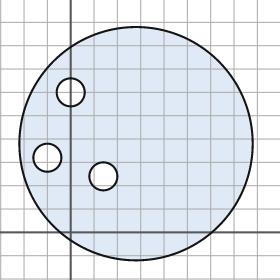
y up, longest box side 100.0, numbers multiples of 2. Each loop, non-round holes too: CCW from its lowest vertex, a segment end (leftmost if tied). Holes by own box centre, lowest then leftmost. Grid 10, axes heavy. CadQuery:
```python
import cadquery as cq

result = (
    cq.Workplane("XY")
    .moveTo(28.0, 38.0)
    .circle(50.0)
    .moveTo(14.0, 24.0)
    .circle(6.0)
    .moveTo(-10.0, 32.0)
    .circle(6.0)
    .moveTo(0.0, 60.0)
    .circle(6.0)
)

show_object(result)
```